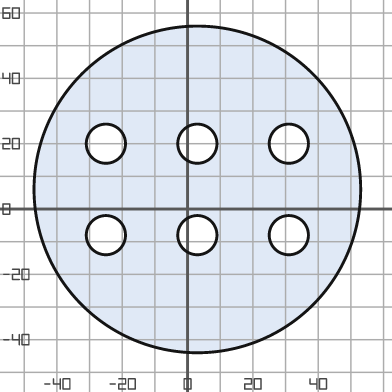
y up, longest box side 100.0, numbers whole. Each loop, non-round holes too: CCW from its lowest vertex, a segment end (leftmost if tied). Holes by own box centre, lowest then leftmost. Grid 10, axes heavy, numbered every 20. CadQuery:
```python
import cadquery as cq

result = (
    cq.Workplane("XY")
    .moveTo(3.0, 6.0)
    .circle(50.0)
    .moveTo(-25.0, -8.0)
    .circle(6.0)
    .moveTo(3.0, -8.0)
    .circle(6.0)
    .moveTo(31.0, -8.0)
    .circle(6.0)
    .moveTo(-25.0, 20.0)
    .circle(6.0)
    .moveTo(3.0, 20.0)
    .circle(6.0)
    .moveTo(31.0, 20.0)
    .circle(6.0)
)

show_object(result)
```